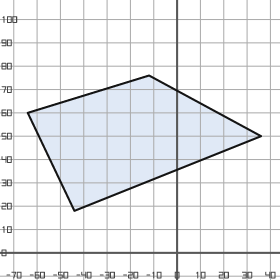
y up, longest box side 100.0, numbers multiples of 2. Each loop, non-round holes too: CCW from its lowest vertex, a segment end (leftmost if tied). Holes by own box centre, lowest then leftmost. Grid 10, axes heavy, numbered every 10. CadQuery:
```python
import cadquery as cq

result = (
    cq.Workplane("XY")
    .moveTo(-44.0, 18.0)
    .lineTo(36.0, 50.0)
    .lineTo(-12.0, 76.0)
    .lineTo(-64.0, 60.0)
    .close()
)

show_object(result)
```